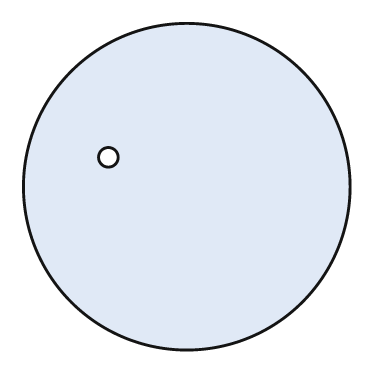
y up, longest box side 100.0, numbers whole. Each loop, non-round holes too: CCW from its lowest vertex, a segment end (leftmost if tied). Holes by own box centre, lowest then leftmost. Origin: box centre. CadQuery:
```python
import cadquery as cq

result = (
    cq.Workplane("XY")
    .moveTo(0.0, 0.0)
    .circle(50.0)
    .moveTo(-24.0, 9.0)
    .circle(3.0)
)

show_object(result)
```